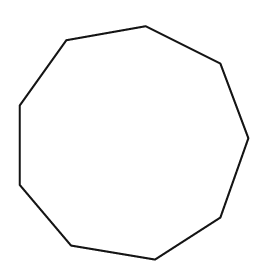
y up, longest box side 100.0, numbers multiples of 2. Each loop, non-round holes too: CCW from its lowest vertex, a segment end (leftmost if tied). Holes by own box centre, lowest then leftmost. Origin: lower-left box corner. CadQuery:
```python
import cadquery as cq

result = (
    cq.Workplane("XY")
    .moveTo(58.0, 0.0)
    .lineTo(86.0, 18.0)
    .lineTo(98.0, 52.0)
    .lineTo(86.0, 84.0)
    .lineTo(54.0, 100.0)
    .lineTo(20.0, 94.0)
    .lineTo(0.0, 66.0)
    .lineTo(0.0, 32.0)
    .lineTo(22.0, 6.0)
    .close()
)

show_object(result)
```